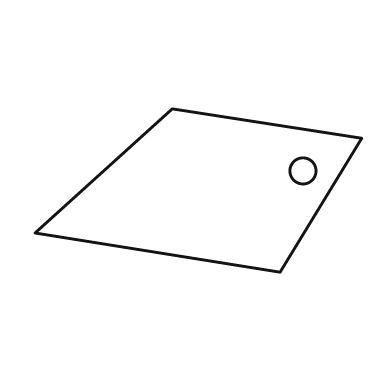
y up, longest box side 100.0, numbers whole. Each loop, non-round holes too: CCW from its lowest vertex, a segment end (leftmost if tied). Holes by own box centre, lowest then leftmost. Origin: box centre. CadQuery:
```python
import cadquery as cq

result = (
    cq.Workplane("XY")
    .moveTo(25.0, -25.0)
    .lineTo(50.0, 16.0)
    .lineTo(-8.0, 25.0)
    .lineTo(-50.0, -13.0)
    .close()
    .moveTo(32.0, 6.0)
    .circle(4.0)
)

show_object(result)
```